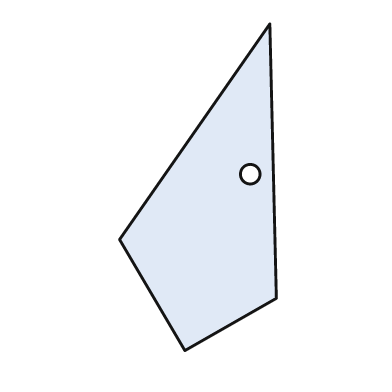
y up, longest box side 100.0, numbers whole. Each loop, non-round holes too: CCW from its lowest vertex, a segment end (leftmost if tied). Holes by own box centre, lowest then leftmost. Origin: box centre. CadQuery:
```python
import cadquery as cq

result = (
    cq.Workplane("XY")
    .moveTo(-4.0, -50.0)
    .lineTo(24.0, -34.0)
    .lineTo(22.0, 50.0)
    .lineTo(-24.0, -16.0)
    .close()
    .moveTo(16.0, 4.0)
    .circle(3.0)
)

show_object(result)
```